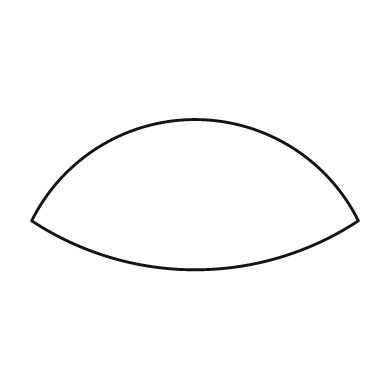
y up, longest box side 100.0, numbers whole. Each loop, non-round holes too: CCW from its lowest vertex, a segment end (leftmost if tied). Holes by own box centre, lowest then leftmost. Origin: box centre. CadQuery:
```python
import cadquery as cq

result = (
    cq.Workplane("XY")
    .moveTo(-50.0, -8.0)
    .threePointArc((0.0, -23.0), (50.0, -8.0))
    .threePointArc((0.0, 23.0), (-50.0, -8.0))
    .close()
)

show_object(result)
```